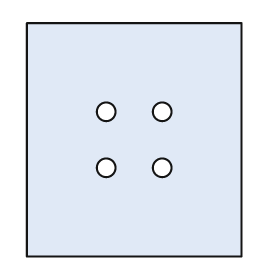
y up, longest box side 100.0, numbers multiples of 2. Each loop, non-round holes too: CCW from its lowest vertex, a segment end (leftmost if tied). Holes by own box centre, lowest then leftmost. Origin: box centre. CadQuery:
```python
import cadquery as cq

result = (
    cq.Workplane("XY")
    .moveTo(-46.0, -50.0)
    .lineTo(46.0, -50.0)
    .lineTo(46.0, 50.0)
    .lineTo(-46.0, 50.0)
    .close()
    .moveTo(-12.0, -12.0)
    .circle(4.0)
    .moveTo(12.0, -12.0)
    .circle(4.0)
    .moveTo(-12.0, 12.0)
    .circle(4.0)
    .moveTo(12.0, 12.0)
    .circle(4.0)
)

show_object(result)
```